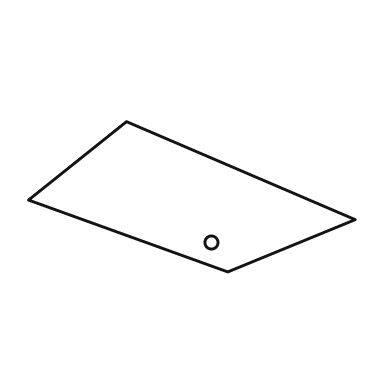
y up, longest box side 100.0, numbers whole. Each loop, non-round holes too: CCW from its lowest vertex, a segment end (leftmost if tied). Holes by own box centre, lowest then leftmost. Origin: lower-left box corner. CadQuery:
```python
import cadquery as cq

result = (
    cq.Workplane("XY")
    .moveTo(61.0, 0.0)
    .lineTo(100.0, 16.0)
    .lineTo(30.0, 46.0)
    .lineTo(0.0, 22.0)
    .close()
    .moveTo(56.0, 9.0)
    .circle(2.0)
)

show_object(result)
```